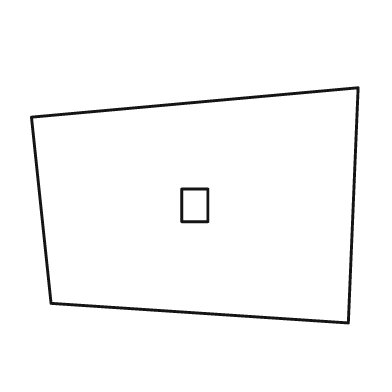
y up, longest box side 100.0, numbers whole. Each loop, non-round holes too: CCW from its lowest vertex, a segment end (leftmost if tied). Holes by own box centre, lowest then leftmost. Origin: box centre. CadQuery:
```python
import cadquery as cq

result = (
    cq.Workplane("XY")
    .moveTo(47.0, -36.0)
    .lineTo(50.0, 36.0)
    .lineTo(-50.0, 27.0)
    .lineTo(-44.0, -30.0)
    .close()
    .moveTo(-4.0, -5.0)
    .lineTo(4.0, -5.0)
    .lineTo(4.0, 5.0)
    .lineTo(-4.0, 5.0)
    .close()
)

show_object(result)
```